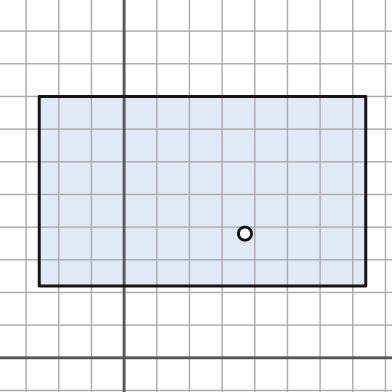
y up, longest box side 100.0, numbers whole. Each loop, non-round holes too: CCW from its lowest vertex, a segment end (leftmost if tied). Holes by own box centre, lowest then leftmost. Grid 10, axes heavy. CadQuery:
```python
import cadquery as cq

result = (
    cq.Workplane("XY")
    .moveTo(-26.0, 22.0)
    .lineTo(74.0, 22.0)
    .lineTo(74.0, 80.0)
    .lineTo(-26.0, 80.0)
    .close()
    .moveTo(37.0, 38.0)
    .circle(2.0)
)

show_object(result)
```